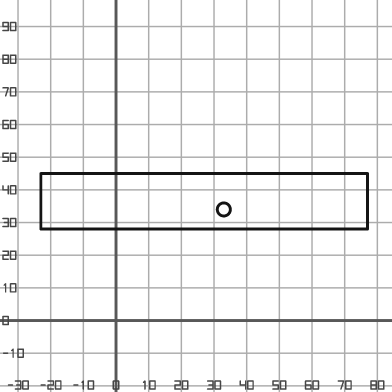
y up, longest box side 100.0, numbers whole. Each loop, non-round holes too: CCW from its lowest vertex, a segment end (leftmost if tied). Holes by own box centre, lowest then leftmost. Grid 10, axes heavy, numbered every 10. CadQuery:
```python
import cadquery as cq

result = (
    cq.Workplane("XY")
    .moveTo(-23.0, 28.0)
    .lineTo(77.0, 28.0)
    .lineTo(77.0, 45.0)
    .lineTo(-23.0, 45.0)
    .close()
    .moveTo(33.0, 34.0)
    .circle(2.0)
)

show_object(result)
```